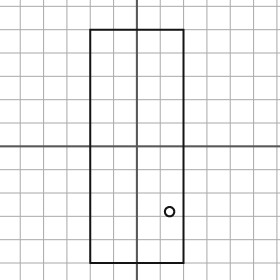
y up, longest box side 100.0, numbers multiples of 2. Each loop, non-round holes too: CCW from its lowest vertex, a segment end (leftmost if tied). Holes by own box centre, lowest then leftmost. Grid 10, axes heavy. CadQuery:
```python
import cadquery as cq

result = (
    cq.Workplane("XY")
    .moveTo(-20.0, -50.0)
    .lineTo(20.0, -50.0)
    .lineTo(20.0, 50.0)
    .lineTo(-20.0, 50.0)
    .close()
    .moveTo(14.0, -28.0)
    .circle(2.0)
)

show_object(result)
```